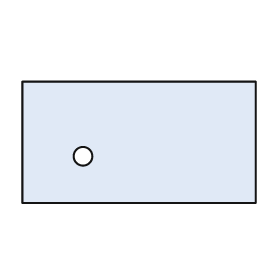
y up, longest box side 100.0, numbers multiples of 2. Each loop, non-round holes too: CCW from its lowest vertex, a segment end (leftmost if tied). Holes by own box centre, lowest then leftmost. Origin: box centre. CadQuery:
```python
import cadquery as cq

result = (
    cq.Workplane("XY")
    .moveTo(-50.0, -26.0)
    .lineTo(50.0, -26.0)
    .lineTo(50.0, 26.0)
    .lineTo(-50.0, 26.0)
    .close()
    .moveTo(-24.0, -6.0)
    .circle(4.0)
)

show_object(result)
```